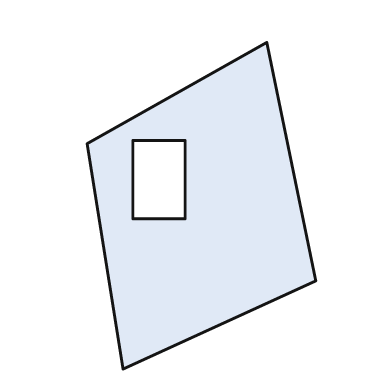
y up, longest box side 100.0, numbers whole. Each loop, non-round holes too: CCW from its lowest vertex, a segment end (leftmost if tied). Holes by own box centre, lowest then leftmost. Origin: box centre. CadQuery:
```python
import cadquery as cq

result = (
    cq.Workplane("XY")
    .moveTo(-24.0, -50.0)
    .lineTo(35.0, -23.0)
    .lineTo(20.0, 50.0)
    .lineTo(-35.0, 19.0)
    .close()
    .moveTo(-21.0, -4.0)
    .lineTo(-5.0, -4.0)
    .lineTo(-5.0, 20.0)
    .lineTo(-21.0, 20.0)
    .close()
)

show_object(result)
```